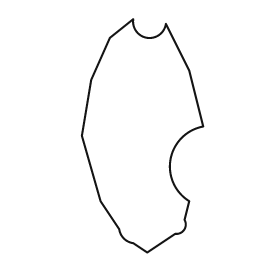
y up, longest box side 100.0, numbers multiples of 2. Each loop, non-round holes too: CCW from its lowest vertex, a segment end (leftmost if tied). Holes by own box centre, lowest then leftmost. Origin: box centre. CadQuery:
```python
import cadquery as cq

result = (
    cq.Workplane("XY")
    .moveTo(2.0, -50.0)
    .lineTo(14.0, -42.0)
    .threePointArc((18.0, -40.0), (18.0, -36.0))
    .lineTo(20.0, -28.0)
    .threePointArc((12.0, -10.0), (26.0, 4.0))
    .lineTo(20.0, 28.0)
    .lineTo(10.0, 48.0)
    .threePointArc((2.0, 42.0), (-4.0, 50.0))
    .lineTo(-14.0, 42.0)
    .lineTo(-22.0, 24.0)
    .lineTo(-26.0, 0.0)
    .lineTo(-18.0, -28.0)
    .lineTo(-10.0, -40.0)
    .threePointArc((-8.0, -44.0), (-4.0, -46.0))
    .close()
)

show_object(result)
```